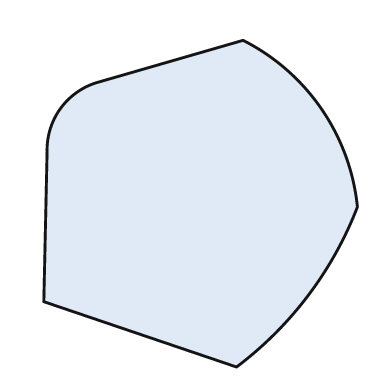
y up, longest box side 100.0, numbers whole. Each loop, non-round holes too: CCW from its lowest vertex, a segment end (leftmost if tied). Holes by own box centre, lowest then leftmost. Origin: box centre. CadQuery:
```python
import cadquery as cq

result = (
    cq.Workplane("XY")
    .moveTo(11.0, -50.0)
    .threePointArc((33.0, -28.0), (48.0, -1.0))
    .threePointArc((37.0, 29.0), (13.0, 50.0))
    .lineTo(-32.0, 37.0)
    .threePointArc((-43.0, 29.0), (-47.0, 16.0))
    .lineTo(-48.0, -30.0)
    .close()
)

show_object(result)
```